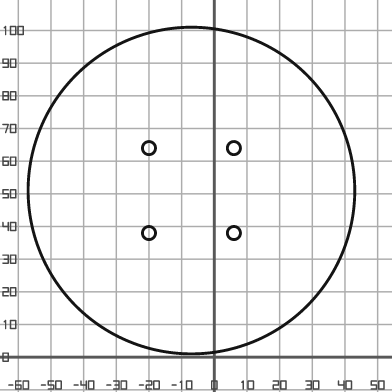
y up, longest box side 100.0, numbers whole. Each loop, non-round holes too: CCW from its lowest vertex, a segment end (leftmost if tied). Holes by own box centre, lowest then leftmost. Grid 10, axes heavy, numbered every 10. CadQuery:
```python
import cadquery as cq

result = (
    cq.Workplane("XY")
    .moveTo(-7.0, 51.0)
    .circle(50.0)
    .moveTo(-20.0, 38.0)
    .circle(2.0)
    .moveTo(6.0, 38.0)
    .circle(2.0)
    .moveTo(-20.0, 64.0)
    .circle(2.0)
    .moveTo(6.0, 64.0)
    .circle(2.0)
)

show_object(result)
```